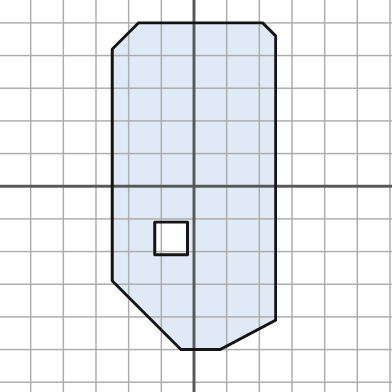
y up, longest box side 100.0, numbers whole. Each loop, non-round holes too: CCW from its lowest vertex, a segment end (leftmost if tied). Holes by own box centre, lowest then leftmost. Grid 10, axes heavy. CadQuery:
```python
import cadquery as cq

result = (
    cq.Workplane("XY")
    .moveTo(-4.0, -50.0)
    .lineTo(8.0, -50.0)
    .lineTo(25.0, -41.0)
    .lineTo(25.0, 46.0)
    .lineTo(21.0, 50.0)
    .lineTo(-17.0, 50.0)
    .lineTo(-25.0, 42.0)
    .lineTo(-25.0, -29.0)
    .close()
    .moveTo(-12.0, -21.0)
    .lineTo(-2.0, -21.0)
    .lineTo(-2.0, -11.0)
    .lineTo(-12.0, -11.0)
    .close()
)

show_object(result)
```